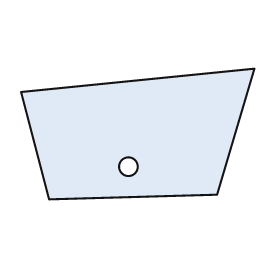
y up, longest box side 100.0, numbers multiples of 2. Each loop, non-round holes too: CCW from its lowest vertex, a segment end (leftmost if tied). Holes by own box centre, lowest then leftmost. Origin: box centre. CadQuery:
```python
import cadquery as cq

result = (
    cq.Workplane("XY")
    .moveTo(-38.0, -28.0)
    .lineTo(34.0, -26.0)
    .lineTo(50.0, 28.0)
    .lineTo(-50.0, 18.0)
    .close()
    .moveTo(-4.0, -14.0)
    .circle(4.0)
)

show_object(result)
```